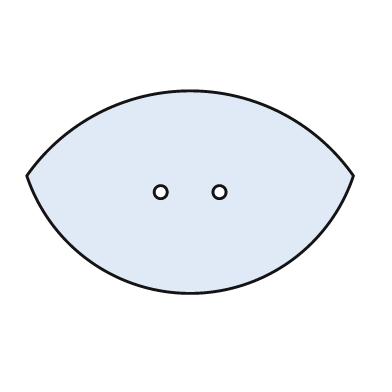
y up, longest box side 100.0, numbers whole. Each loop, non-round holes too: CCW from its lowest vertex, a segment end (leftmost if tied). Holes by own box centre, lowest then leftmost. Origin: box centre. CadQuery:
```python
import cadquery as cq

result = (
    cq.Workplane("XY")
    .moveTo(-50.0, 5.0)
    .threePointArc((0.0, -31.0), (50.0, 5.0))
    .threePointArc((0.0, 31.0), (-50.0, 5.0))
    .close()
    .moveTo(-9.0, 0.0)
    .circle(2.0)
    .moveTo(9.0, 0.0)
    .circle(2.0)
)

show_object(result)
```